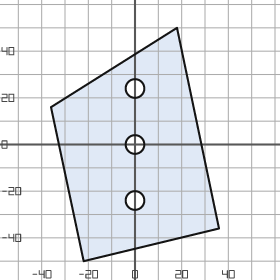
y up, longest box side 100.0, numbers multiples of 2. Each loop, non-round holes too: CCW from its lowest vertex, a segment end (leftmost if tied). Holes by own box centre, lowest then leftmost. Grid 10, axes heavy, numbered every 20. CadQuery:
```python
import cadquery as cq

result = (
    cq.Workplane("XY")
    .moveTo(-22.0, -50.0)
    .lineTo(36.0, -36.0)
    .lineTo(18.0, 50.0)
    .lineTo(-36.0, 16.0)
    .close()
    .moveTo(0.0, -24.0)
    .circle(4.0)
    .moveTo(0.0, 0.0)
    .circle(4.0)
    .moveTo(0.0, 24.0)
    .circle(4.0)
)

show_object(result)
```